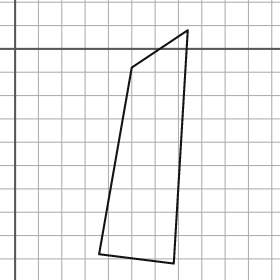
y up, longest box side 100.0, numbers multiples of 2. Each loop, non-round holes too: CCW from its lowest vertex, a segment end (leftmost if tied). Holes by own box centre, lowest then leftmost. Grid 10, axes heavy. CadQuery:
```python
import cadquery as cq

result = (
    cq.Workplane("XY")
    .moveTo(68.0, -92.0)
    .lineTo(74.0, 8.0)
    .lineTo(50.0, -8.0)
    .lineTo(36.0, -88.0)
    .close()
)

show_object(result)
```